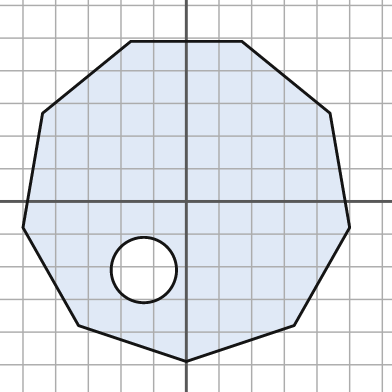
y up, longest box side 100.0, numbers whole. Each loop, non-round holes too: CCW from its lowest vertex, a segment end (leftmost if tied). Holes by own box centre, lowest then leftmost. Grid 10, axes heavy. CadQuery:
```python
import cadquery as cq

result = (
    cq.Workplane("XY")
    .moveTo(0.0, -49.0)
    .lineTo(33.0, -38.0)
    .lineTo(50.0, -8.0)
    .lineTo(44.0, 27.0)
    .lineTo(17.0, 49.0)
    .lineTo(-17.0, 49.0)
    .lineTo(-44.0, 27.0)
    .lineTo(-50.0, -8.0)
    .lineTo(-33.0, -38.0)
    .close()
    .moveTo(-13.0, -21.0)
    .circle(10.0)
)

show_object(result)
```